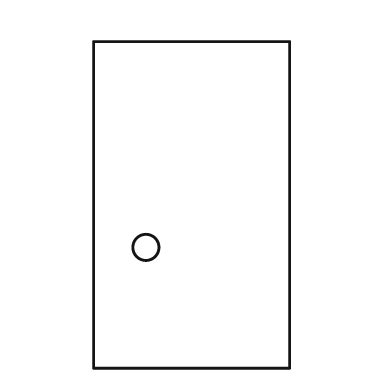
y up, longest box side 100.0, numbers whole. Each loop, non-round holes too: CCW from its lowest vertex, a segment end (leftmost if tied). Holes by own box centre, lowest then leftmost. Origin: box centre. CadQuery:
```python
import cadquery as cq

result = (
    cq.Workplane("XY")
    .moveTo(-30.0, -50.0)
    .lineTo(30.0, -50.0)
    .lineTo(30.0, 50.0)
    .lineTo(-30.0, 50.0)
    .close()
    .moveTo(-14.0, -13.0)
    .circle(4.0)
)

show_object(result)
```